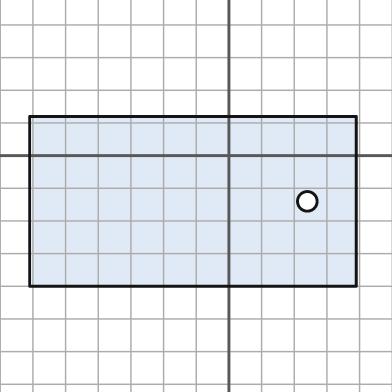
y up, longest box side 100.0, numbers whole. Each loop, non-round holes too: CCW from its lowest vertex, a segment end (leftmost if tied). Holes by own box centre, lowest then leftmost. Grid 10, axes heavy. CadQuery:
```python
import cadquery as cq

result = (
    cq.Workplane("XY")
    .moveTo(-61.0, -40.0)
    .lineTo(39.0, -40.0)
    .lineTo(39.0, 12.0)
    .lineTo(-61.0, 12.0)
    .close()
    .moveTo(24.0, -14.0)
    .circle(3.0)
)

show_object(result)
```